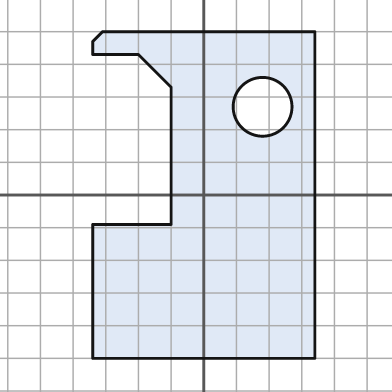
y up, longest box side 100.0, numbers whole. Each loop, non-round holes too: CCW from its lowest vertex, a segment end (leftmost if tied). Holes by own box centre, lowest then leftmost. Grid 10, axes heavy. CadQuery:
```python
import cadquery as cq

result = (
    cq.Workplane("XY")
    .moveTo(-34.0, -50.0)
    .lineTo(34.0, -50.0)
    .lineTo(34.0, 50.0)
    .lineTo(-31.0, 50.0)
    .lineTo(-34.0, 47.0)
    .lineTo(-34.0, 43.0)
    .lineTo(-20.0, 43.0)
    .lineTo(-10.0, 33.0)
    .lineTo(-10.0, -9.0)
    .lineTo(-34.0, -9.0)
    .close()
    .moveTo(18.0, 27.0)
    .circle(9.0)
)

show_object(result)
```